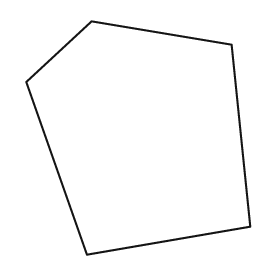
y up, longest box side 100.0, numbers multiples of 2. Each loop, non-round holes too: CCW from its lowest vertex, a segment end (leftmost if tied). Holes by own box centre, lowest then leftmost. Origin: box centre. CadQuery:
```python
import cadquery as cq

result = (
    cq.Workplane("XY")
    .moveTo(-22.0, -50.0)
    .lineTo(48.0, -38.0)
    .lineTo(40.0, 40.0)
    .lineTo(-20.0, 50.0)
    .lineTo(-48.0, 24.0)
    .close()
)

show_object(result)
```